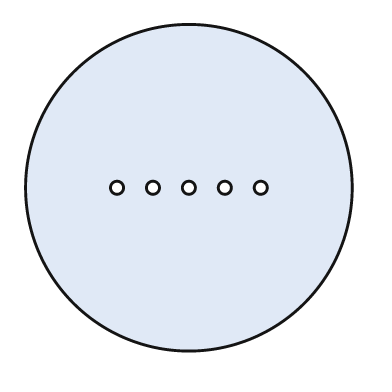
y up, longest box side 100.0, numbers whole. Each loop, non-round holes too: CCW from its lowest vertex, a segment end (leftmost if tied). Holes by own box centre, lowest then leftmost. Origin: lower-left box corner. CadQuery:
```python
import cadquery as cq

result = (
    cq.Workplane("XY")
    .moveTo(50.0, 50.0)
    .circle(50.0)
    .moveTo(28.0, 50.0)
    .circle(2.0)
    .moveTo(39.0, 50.0)
    .circle(2.0)
    .moveTo(50.0, 50.0)
    .circle(2.0)
    .moveTo(61.0, 50.0)
    .circle(2.0)
    .moveTo(72.0, 50.0)
    .circle(2.0)
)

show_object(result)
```